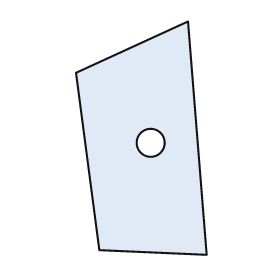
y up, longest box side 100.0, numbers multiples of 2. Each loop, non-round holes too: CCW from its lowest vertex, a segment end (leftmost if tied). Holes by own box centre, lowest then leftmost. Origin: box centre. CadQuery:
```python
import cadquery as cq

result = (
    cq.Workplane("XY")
    .moveTo(28.0, -50.0)
    .lineTo(20.0, 50.0)
    .lineTo(-28.0, 28.0)
    .lineTo(-18.0, -48.0)
    .close()
    .moveTo(4.0, -2.0)
    .circle(6.0)
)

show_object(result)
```